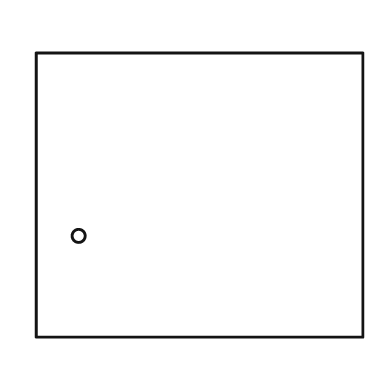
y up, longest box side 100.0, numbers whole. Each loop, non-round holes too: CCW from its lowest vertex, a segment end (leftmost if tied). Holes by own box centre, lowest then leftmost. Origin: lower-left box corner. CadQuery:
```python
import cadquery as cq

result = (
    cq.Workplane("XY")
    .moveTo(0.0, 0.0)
    .lineTo(100.0, 0.0)
    .lineTo(100.0, 87.0)
    .lineTo(0.0, 87.0)
    .close()
    .moveTo(13.0, 31.0)
    .circle(2.0)
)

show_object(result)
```